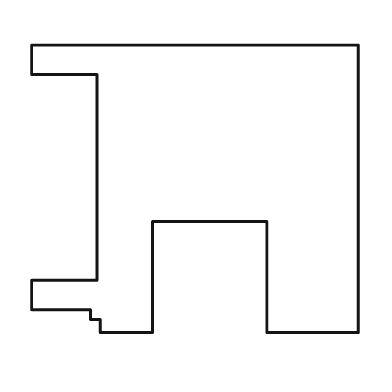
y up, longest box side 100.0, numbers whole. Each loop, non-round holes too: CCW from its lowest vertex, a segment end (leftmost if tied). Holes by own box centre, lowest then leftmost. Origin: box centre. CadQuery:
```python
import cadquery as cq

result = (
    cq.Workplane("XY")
    .moveTo(-29.0, -44.0)
    .lineTo(-13.0, -44.0)
    .lineTo(-13.0, -10.0)
    .lineTo(22.0, -10.0)
    .lineTo(22.0, -44.0)
    .lineTo(50.0, -44.0)
    .lineTo(50.0, 44.0)
    .lineTo(-50.0, 44.0)
    .lineTo(-50.0, 35.0)
    .lineTo(-30.0, 35.0)
    .lineTo(-30.0, -28.0)
    .lineTo(-50.0, -28.0)
    .lineTo(-50.0, -37.0)
    .lineTo(-32.0, -37.0)
    .lineTo(-32.0, -40.0)
    .lineTo(-29.0, -40.0)
    .close()
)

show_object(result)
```